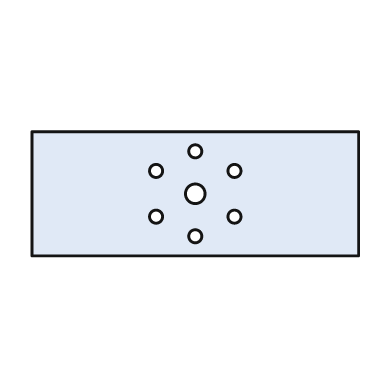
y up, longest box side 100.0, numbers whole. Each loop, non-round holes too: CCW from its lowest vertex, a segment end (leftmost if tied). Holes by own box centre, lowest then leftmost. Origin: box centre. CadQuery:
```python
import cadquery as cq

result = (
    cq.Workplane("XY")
    .moveTo(-50.0, -19.0)
    .lineTo(50.0, -19.0)
    .lineTo(50.0, 19.0)
    .lineTo(-50.0, 19.0)
    .close()
    .moveTo(0.0, -13.0)
    .circle(2.0)
    .moveTo(-12.0, -7.0)
    .circle(2.0)
    .moveTo(12.0, -7.0)
    .circle(2.0)
    .moveTo(0.0, 0.0)
    .circle(3.0)
    .moveTo(-12.0, 7.0)
    .circle(2.0)
    .moveTo(12.0, 7.0)
    .circle(2.0)
    .moveTo(0.0, 13.0)
    .circle(2.0)
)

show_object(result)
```